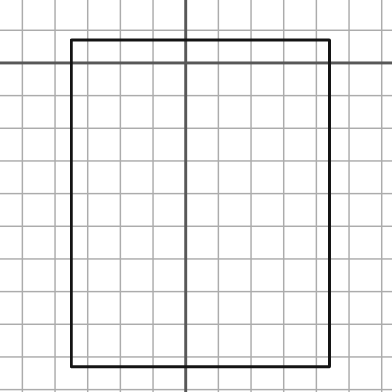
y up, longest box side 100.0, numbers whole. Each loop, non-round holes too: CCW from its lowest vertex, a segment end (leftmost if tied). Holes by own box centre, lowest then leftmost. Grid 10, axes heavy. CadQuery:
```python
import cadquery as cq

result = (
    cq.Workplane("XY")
    .moveTo(-35.0, -93.0)
    .lineTo(44.0, -93.0)
    .lineTo(44.0, 7.0)
    .lineTo(-35.0, 7.0)
    .close()
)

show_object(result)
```